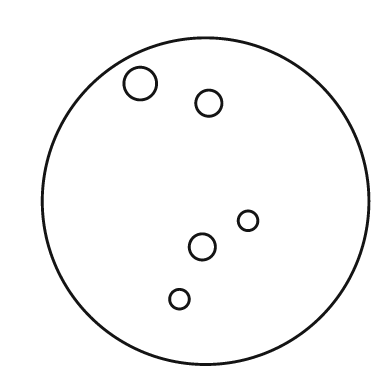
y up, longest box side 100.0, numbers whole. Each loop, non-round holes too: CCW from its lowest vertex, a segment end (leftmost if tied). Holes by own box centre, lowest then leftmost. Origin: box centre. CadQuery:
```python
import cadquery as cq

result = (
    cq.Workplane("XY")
    .moveTo(0.0, 0.0)
    .circle(50.0)
    .moveTo(-8.0, -30.0)
    .circle(3.0)
    .moveTo(-1.0, -14.0)
    .circle(4.0)
    .moveTo(13.0, -6.0)
    .circle(3.0)
    .moveTo(1.0, 30.0)
    .circle(4.0)
    .moveTo(-20.0, 36.0)
    .circle(5.0)
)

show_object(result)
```